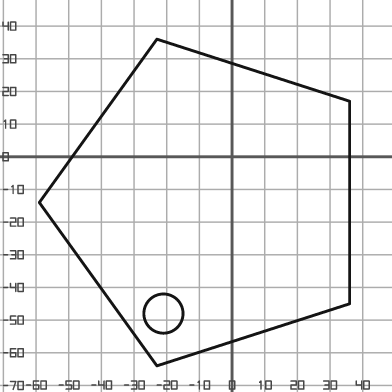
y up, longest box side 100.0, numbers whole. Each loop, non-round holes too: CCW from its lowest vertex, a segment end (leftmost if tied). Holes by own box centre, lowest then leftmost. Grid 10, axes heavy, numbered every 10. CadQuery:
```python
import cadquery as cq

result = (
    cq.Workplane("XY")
    .moveTo(-23.0, -64.0)
    .lineTo(36.0, -45.0)
    .lineTo(36.0, 17.0)
    .lineTo(-23.0, 36.0)
    .lineTo(-59.0, -14.0)
    .close()
    .moveTo(-21.0, -48.0)
    .circle(6.0)
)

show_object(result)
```